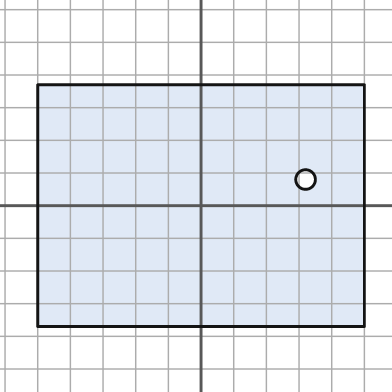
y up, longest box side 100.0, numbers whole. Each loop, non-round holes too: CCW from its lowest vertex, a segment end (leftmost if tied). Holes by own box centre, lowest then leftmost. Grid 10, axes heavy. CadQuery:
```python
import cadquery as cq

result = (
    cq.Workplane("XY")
    .moveTo(-50.0, -37.0)
    .lineTo(50.0, -37.0)
    .lineTo(50.0, 37.0)
    .lineTo(-50.0, 37.0)
    .close()
    .moveTo(32.0, 8.0)
    .circle(3.0)
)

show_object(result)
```